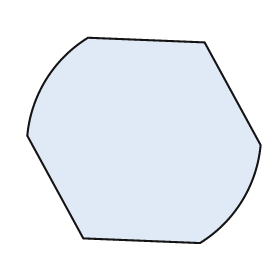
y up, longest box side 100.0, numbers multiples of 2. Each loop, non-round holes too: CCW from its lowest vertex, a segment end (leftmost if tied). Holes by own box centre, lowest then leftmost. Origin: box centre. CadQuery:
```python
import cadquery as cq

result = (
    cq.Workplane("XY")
    .moveTo(24.0, -44.0)
    .threePointArc((42.0, -26.0), (50.0, -2.0))
    .lineTo(26.0, 42.0)
    .lineTo(-24.0, 44.0)
    .threePointArc((-42.0, 26.0), (-50.0, 2.0))
    .lineTo(-26.0, -42.0)
    .close()
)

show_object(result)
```